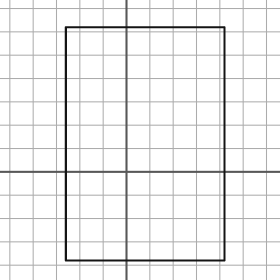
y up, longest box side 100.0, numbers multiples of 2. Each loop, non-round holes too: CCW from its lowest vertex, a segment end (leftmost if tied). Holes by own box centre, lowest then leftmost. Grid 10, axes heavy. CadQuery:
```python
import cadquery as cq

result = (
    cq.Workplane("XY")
    .moveTo(-26.0, -38.0)
    .lineTo(42.0, -38.0)
    .lineTo(42.0, 62.0)
    .lineTo(-26.0, 62.0)
    .close()
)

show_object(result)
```